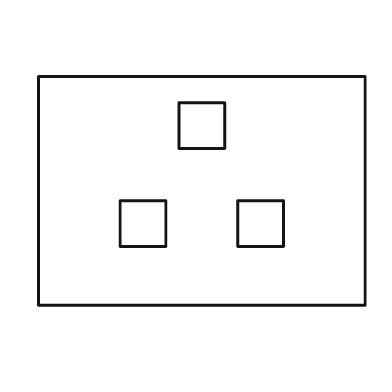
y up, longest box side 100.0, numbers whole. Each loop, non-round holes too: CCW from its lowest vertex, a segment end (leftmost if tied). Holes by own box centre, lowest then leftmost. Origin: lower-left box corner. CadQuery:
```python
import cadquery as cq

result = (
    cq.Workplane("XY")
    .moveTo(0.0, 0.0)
    .lineTo(100.0, 0.0)
    .lineTo(100.0, 70.0)
    .lineTo(0.0, 70.0)
    .close()
    .moveTo(25.0, 18.0)
    .lineTo(39.0, 18.0)
    .lineTo(39.0, 32.0)
    .lineTo(25.0, 32.0)
    .close()
    .moveTo(61.0, 18.0)
    .lineTo(75.0, 18.0)
    .lineTo(75.0, 32.0)
    .lineTo(61.0, 32.0)
    .close()
    .moveTo(43.0, 48.0)
    .lineTo(57.0, 48.0)
    .lineTo(57.0, 62.0)
    .lineTo(43.0, 62.0)
    .close()
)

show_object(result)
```